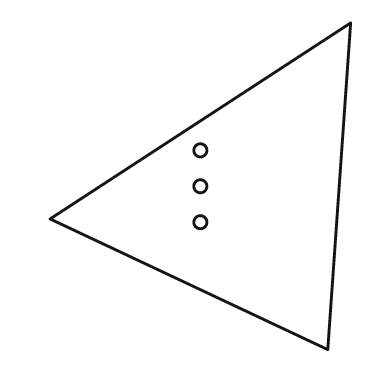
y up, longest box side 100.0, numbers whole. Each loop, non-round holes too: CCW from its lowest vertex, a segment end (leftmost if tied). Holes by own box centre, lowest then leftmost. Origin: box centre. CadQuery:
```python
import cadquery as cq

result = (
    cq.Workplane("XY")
    .moveTo(39.0, -50.0)
    .lineTo(46.0, 50.0)
    .lineTo(-46.0, -10.0)
    .close()
    .moveTo(0.0, -11.0)
    .circle(2.0)
    .moveTo(0.0, 0.0)
    .circle(2.0)
    .moveTo(0.0, 11.0)
    .circle(2.0)
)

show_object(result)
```